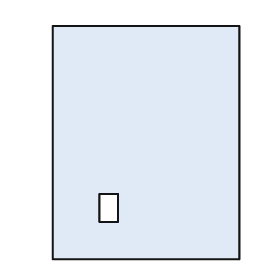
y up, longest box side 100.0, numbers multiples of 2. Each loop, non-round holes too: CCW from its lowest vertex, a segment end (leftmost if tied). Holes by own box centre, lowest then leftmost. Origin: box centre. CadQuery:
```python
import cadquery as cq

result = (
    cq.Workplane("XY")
    .moveTo(-40.0, -50.0)
    .lineTo(40.0, -50.0)
    .lineTo(40.0, 50.0)
    .lineTo(-40.0, 50.0)
    .close()
    .moveTo(-20.0, -34.0)
    .lineTo(-12.0, -34.0)
    .lineTo(-12.0, -22.0)
    .lineTo(-20.0, -22.0)
    .close()
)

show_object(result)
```